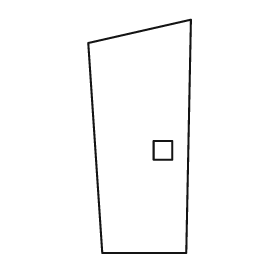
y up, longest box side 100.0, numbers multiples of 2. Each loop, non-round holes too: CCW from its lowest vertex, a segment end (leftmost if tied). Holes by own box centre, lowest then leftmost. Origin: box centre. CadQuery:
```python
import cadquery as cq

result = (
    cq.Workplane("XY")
    .moveTo(-16.0, -50.0)
    .lineTo(20.0, -50.0)
    .lineTo(22.0, 50.0)
    .lineTo(-22.0, 40.0)
    .close()
    .moveTo(6.0, -10.0)
    .lineTo(14.0, -10.0)
    .lineTo(14.0, -2.0)
    .lineTo(6.0, -2.0)
    .close()
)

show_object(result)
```